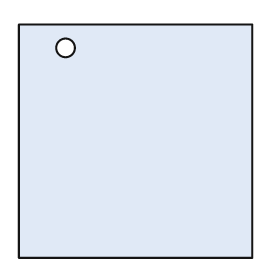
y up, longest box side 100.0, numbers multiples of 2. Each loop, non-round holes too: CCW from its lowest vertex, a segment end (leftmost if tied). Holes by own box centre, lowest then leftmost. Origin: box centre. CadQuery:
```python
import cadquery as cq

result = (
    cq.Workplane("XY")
    .moveTo(-50.0, -50.0)
    .lineTo(50.0, -50.0)
    .lineTo(50.0, 50.0)
    .lineTo(-50.0, 50.0)
    .close()
    .moveTo(-30.0, 40.0)
    .circle(4.0)
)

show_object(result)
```